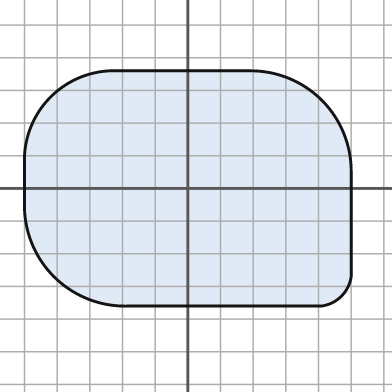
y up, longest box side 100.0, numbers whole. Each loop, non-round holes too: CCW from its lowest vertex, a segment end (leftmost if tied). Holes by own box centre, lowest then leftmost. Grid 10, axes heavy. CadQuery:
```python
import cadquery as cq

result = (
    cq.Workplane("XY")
    .moveTo(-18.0, -36.0)
    .lineTo(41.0, -36.0)
    .threePointArc((47.0, -33.0), (50.0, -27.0))
    .lineTo(50.0, 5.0)
    .threePointArc((41.0, 27.0), (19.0, 36.0))
    .lineTo(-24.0, 36.0)
    .threePointArc((-42.0, 28.0), (-50.0, 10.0))
    .lineTo(-50.0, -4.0)
    .threePointArc((-41.0, -27.0), (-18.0, -36.0))
    .close()
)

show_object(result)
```